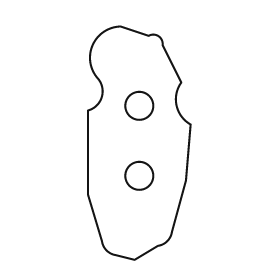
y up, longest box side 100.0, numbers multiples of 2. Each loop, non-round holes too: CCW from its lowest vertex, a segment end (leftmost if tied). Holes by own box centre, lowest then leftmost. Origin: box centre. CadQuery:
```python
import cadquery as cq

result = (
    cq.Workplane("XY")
    .moveTo(-2.0, -50.0)
    .lineTo(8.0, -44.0)
    .threePointArc((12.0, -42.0), (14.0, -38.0))
    .lineTo(20.0, -16.0)
    .lineTo(22.0, 8.0)
    .threePointArc((16.0, 16.0), (18.0, 26.0))
    .lineTo(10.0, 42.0)
    .threePointArc((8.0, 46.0), (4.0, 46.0))
    .lineTo(-8.0, 50.0)
    .threePointArc((-20.0, 42.0), (-18.0, 28.0))
    .threePointArc((-16.0, 20.0), (-22.0, 14.0))
    .lineTo(-22.0, -22.0)
    .lineTo(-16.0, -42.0)
    .threePointArc((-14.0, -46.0), (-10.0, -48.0))
    .close()
    .moveTo(0.0, -14.0)
    .circle(6.0)
    .moveTo(0.0, 16.0)
    .circle(6.0)
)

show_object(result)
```